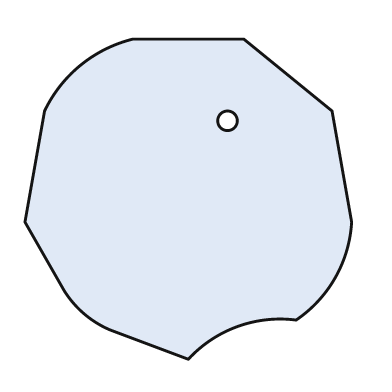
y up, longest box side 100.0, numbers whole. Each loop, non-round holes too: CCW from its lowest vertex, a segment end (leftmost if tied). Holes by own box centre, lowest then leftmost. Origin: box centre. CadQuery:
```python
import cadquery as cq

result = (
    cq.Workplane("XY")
    .moveTo(0.0, -49.0)
    .threePointArc((15.0, -39.0), (33.0, -37.0))
    .threePointArc((45.0, -24.0), (50.0, -7.0))
    .lineTo(44.0, 27.0)
    .lineTo(17.0, 49.0)
    .lineTo(-17.0, 49.0)
    .threePointArc((-33.0, 41.0), (-44.0, 27.0))
    .lineTo(-50.0, -7.0)
    .lineTo(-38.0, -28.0)
    .threePointArc((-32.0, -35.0), (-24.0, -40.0))
    .close()
    .moveTo(12.0, 24.0)
    .circle(3.0)
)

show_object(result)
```